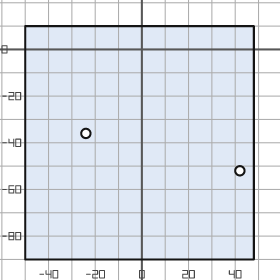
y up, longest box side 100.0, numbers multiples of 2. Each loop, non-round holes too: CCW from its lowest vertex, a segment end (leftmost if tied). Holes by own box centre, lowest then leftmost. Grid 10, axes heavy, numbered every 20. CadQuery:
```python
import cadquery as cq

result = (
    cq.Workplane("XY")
    .moveTo(-50.0, -90.0)
    .lineTo(48.0, -90.0)
    .lineTo(48.0, 10.0)
    .lineTo(-50.0, 10.0)
    .close()
    .moveTo(42.0, -52.0)
    .circle(2.0)
    .moveTo(-24.0, -36.0)
    .circle(2.0)
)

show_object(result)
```